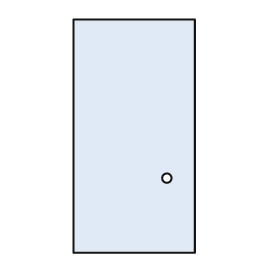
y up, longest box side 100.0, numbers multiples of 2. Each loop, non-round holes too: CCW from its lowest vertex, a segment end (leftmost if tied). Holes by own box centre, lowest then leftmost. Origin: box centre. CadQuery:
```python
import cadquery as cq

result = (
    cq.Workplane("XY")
    .moveTo(-26.0, -50.0)
    .lineTo(26.0, -50.0)
    .lineTo(26.0, 50.0)
    .lineTo(-26.0, 50.0)
    .close()
    .moveTo(14.0, -18.0)
    .circle(2.0)
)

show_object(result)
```